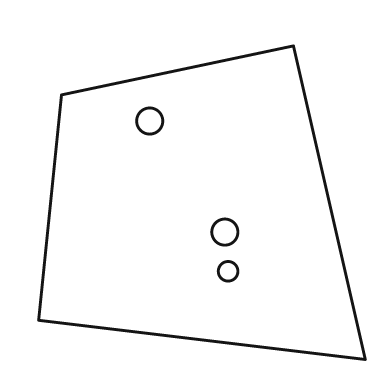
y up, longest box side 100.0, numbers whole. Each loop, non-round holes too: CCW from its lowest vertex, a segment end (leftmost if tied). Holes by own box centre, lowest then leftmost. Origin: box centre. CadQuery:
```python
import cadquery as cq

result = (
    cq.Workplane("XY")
    .moveTo(50.0, -48.0)
    .lineTo(28.0, 48.0)
    .lineTo(-43.0, 33.0)
    .lineTo(-50.0, -36.0)
    .close()
    .moveTo(8.0, -21.0)
    .circle(3.0)
    .moveTo(7.0, -9.0)
    .circle(4.0)
    .moveTo(-16.0, 25.0)
    .circle(4.0)
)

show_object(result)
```